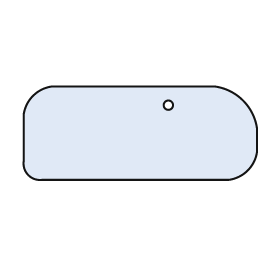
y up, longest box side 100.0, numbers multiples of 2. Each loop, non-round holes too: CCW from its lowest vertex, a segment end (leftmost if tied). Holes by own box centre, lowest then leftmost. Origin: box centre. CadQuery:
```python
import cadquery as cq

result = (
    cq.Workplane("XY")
    .moveTo(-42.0, -20.0)
    .lineTo(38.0, -20.0)
    .threePointArc((46.0, -16.0), (50.0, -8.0))
    .lineTo(50.0, 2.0)
    .threePointArc((44.0, 14.0), (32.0, 20.0))
    .lineTo(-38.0, 20.0)
    .threePointArc((-46.0, 16.0), (-50.0, 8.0))
    .lineTo(-50.0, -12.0)
    .threePointArc((-48.0, -18.0), (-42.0, -20.0))
    .close()
    .moveTo(12.0, 12.0)
    .circle(2.0)
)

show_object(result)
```